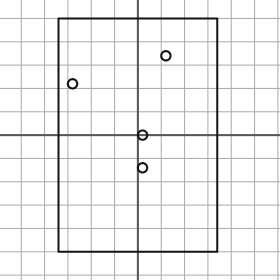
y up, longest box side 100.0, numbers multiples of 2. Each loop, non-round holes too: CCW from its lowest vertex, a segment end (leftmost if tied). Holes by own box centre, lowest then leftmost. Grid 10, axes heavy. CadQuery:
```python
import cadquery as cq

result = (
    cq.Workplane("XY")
    .moveTo(-34.0, -50.0)
    .lineTo(34.0, -50.0)
    .lineTo(34.0, 50.0)
    .lineTo(-34.0, 50.0)
    .close()
    .moveTo(2.0, -14.0)
    .circle(2.0)
    .moveTo(2.0, 0.0)
    .circle(2.0)
    .moveTo(-28.0, 22.0)
    .circle(2.0)
    .moveTo(12.0, 34.0)
    .circle(2.0)
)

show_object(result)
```